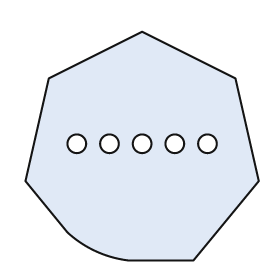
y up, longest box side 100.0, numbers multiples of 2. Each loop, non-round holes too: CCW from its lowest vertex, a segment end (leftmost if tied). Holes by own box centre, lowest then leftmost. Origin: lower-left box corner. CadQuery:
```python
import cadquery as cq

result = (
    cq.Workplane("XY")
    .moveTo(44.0, 0.0)
    .lineTo(72.0, 0.0)
    .lineTo(100.0, 34.0)
    .lineTo(90.0, 78.0)
    .lineTo(50.0, 98.0)
    .lineTo(10.0, 78.0)
    .lineTo(0.0, 34.0)
    .lineTo(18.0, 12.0)
    .threePointArc((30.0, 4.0), (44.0, 0.0))
    .close()
    .moveTo(22.0, 50.0)
    .circle(4.0)
    .moveTo(36.0, 50.0)
    .circle(4.0)
    .moveTo(50.0, 50.0)
    .circle(4.0)
    .moveTo(64.0, 50.0)
    .circle(4.0)
    .moveTo(78.0, 50.0)
    .circle(4.0)
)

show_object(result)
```